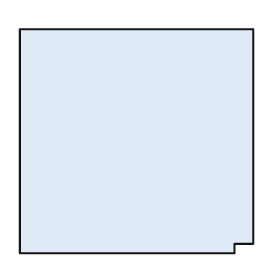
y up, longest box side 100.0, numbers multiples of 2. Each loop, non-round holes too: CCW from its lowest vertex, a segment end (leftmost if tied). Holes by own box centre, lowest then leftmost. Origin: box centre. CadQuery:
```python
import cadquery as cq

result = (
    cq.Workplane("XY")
    .moveTo(-50.0, -48.0)
    .lineTo(42.0, -48.0)
    .lineTo(42.0, -44.0)
    .lineTo(50.0, -44.0)
    .lineTo(50.0, 48.0)
    .lineTo(-50.0, 48.0)
    .close()
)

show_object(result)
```